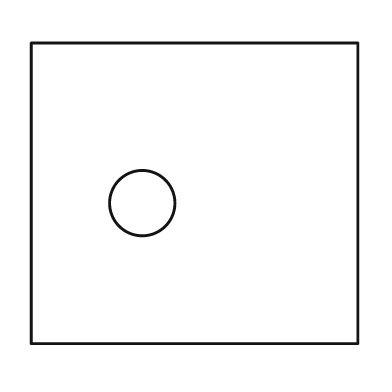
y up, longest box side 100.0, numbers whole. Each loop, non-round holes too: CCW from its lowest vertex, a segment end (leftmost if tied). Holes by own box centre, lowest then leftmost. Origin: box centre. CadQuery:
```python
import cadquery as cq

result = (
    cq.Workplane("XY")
    .moveTo(-50.0, -46.0)
    .lineTo(50.0, -46.0)
    .lineTo(50.0, 46.0)
    .lineTo(-50.0, 46.0)
    .close()
    .moveTo(-16.0, -3.0)
    .circle(10.0)
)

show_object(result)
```